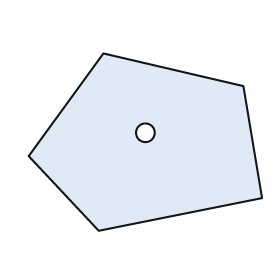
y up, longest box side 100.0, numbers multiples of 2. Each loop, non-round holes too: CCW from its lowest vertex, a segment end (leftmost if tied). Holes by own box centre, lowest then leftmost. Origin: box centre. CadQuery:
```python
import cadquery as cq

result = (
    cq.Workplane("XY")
    .moveTo(-20.0, -38.0)
    .lineTo(50.0, -24.0)
    .lineTo(42.0, 24.0)
    .lineTo(-18.0, 38.0)
    .lineTo(-50.0, -6.0)
    .close()
    .moveTo(0.0, 4.0)
    .circle(4.0)
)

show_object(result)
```